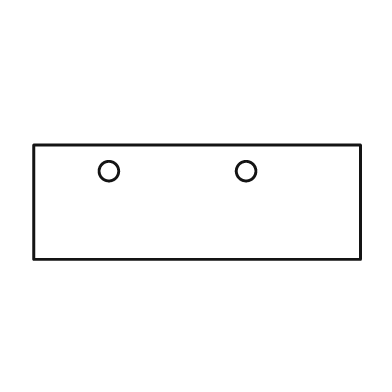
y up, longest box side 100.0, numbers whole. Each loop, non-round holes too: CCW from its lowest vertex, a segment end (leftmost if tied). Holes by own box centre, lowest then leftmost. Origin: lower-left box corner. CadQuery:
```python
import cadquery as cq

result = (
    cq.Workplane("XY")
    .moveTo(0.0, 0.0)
    .lineTo(100.0, 0.0)
    .lineTo(100.0, 35.0)
    .lineTo(0.0, 35.0)
    .close()
    .moveTo(23.0, 27.0)
    .circle(3.0)
    .moveTo(65.0, 27.0)
    .circle(3.0)
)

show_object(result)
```